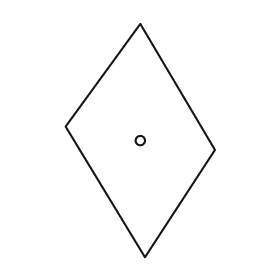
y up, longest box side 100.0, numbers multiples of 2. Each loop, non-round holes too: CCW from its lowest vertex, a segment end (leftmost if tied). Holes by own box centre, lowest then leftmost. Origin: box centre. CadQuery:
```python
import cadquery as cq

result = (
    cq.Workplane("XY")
    .moveTo(2.0, -50.0)
    .lineTo(32.0, -4.0)
    .lineTo(0.0, 50.0)
    .lineTo(-32.0, 6.0)
    .close()
    .moveTo(0.0, 0.0)
    .circle(2.0)
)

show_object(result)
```